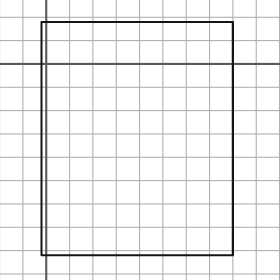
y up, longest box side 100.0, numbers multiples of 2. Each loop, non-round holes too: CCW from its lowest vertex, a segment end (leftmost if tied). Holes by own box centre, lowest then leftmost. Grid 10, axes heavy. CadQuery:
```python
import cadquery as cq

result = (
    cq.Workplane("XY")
    .moveTo(-2.0, -82.0)
    .lineTo(80.0, -82.0)
    .lineTo(80.0, 18.0)
    .lineTo(-2.0, 18.0)
    .close()
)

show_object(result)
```